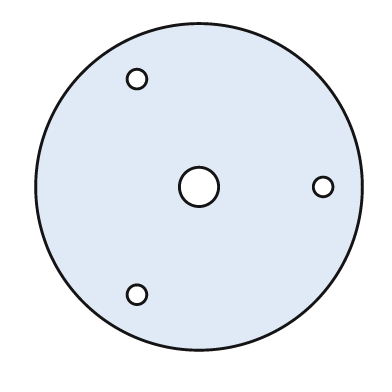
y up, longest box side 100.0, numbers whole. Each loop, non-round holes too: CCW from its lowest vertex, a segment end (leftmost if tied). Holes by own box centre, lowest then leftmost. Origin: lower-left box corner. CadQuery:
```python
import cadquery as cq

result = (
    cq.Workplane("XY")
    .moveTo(50.0, 50.0)
    .circle(50.0)
    .moveTo(31.0, 17.0)
    .circle(3.0)
    .moveTo(50.0, 50.0)
    .circle(6.0)
    .moveTo(88.0, 50.0)
    .circle(3.0)
    .moveTo(31.0, 83.0)
    .circle(3.0)
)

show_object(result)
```